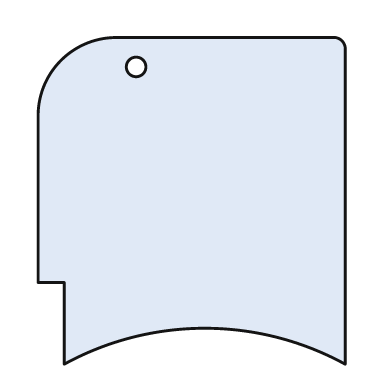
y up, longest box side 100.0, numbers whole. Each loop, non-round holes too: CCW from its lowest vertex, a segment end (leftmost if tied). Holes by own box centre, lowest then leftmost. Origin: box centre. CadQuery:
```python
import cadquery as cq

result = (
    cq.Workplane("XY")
    .moveTo(-39.0, -50.0)
    .threePointArc((4.0, -39.0), (47.0, -50.0))
    .lineTo(47.0, 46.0)
    .threePointArc((46.0, 49.0), (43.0, 50.0))
    .lineTo(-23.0, 50.0)
    .threePointArc((-40.0, 43.0), (-47.0, 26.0))
    .lineTo(-47.0, -25.0)
    .lineTo(-39.0, -25.0)
    .close()
    .moveTo(-17.0, 41.0)
    .circle(3.0)
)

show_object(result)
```